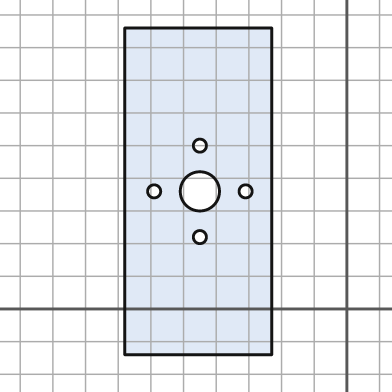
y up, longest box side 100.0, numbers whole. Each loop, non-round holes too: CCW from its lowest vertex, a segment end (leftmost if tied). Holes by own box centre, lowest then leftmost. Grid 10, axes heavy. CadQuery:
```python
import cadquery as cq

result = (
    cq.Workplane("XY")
    .moveTo(-68.0, -14.0)
    .lineTo(-23.0, -14.0)
    .lineTo(-23.0, 86.0)
    .lineTo(-68.0, 86.0)
    .close()
    .moveTo(-45.0, 22.0)
    .circle(2.0)
    .moveTo(-59.0, 36.0)
    .circle(2.0)
    .moveTo(-45.0, 36.0)
    .circle(6.0)
    .moveTo(-31.0, 36.0)
    .circle(2.0)
    .moveTo(-45.0, 50.0)
    .circle(2.0)
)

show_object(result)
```